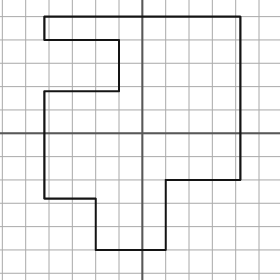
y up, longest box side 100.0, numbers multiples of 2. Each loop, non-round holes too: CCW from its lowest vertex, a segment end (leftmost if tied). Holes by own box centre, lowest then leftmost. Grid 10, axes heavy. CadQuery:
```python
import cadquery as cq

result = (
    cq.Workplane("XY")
    .moveTo(-20.0, -50.0)
    .lineTo(10.0, -50.0)
    .lineTo(10.0, -20.0)
    .lineTo(42.0, -20.0)
    .lineTo(42.0, 50.0)
    .lineTo(-42.0, 50.0)
    .lineTo(-42.0, 40.0)
    .lineTo(-10.0, 40.0)
    .lineTo(-10.0, 18.0)
    .lineTo(-42.0, 18.0)
    .lineTo(-42.0, -28.0)
    .lineTo(-20.0, -28.0)
    .close()
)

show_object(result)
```